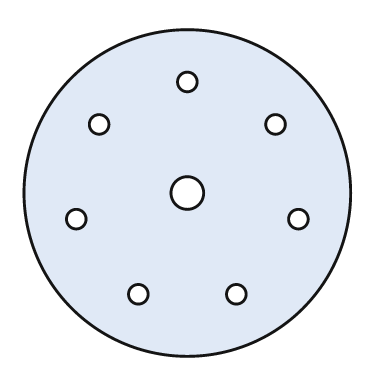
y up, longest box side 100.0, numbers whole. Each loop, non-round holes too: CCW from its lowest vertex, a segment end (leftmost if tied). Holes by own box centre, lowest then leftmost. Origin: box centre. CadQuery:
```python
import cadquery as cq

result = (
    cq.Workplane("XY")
    .moveTo(0.0, 0.0)
    .circle(50.0)
    .moveTo(-15.0, -31.0)
    .circle(3.0)
    .moveTo(15.0, -31.0)
    .circle(3.0)
    .moveTo(-34.0, -8.0)
    .circle(3.0)
    .moveTo(34.0, -8.0)
    .circle(3.0)
    .moveTo(0.0, 0.0)
    .circle(5.0)
    .moveTo(-27.0, 21.0)
    .circle(3.0)
    .moveTo(27.0, 21.0)
    .circle(3.0)
    .moveTo(0.0, 34.0)
    .circle(3.0)
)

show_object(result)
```